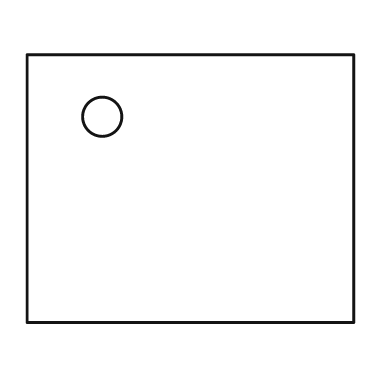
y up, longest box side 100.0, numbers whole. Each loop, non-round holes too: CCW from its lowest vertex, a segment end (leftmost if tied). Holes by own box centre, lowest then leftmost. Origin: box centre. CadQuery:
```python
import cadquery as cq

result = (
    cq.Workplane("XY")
    .moveTo(-50.0, -41.0)
    .lineTo(50.0, -41.0)
    .lineTo(50.0, 41.0)
    .lineTo(-50.0, 41.0)
    .close()
    .moveTo(-27.0, 22.0)
    .circle(6.0)
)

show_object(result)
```